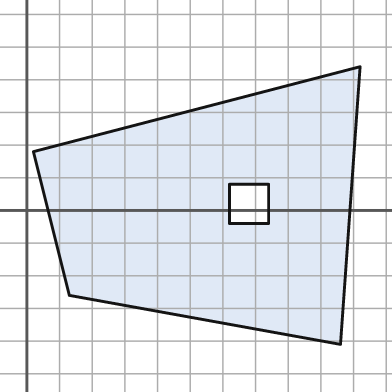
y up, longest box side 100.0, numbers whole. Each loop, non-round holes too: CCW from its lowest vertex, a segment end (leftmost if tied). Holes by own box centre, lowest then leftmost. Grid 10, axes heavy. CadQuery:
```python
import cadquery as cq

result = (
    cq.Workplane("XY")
    .moveTo(96.0, -41.0)
    .lineTo(102.0, 44.0)
    .lineTo(2.0, 18.0)
    .lineTo(13.0, -26.0)
    .close()
    .moveTo(62.0, -4.0)
    .lineTo(74.0, -4.0)
    .lineTo(74.0, 8.0)
    .lineTo(62.0, 8.0)
    .close()
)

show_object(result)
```